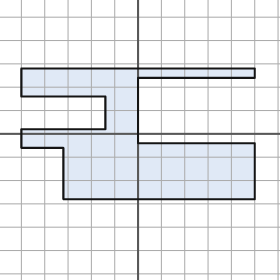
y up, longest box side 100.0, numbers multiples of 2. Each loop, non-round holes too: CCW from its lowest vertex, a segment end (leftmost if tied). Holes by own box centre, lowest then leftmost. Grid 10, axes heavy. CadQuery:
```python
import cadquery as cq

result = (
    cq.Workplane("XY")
    .moveTo(-32.0, -28.0)
    .lineTo(50.0, -28.0)
    .lineTo(50.0, -4.0)
    .lineTo(0.0, -4.0)
    .lineTo(0.0, 24.0)
    .lineTo(50.0, 24.0)
    .lineTo(50.0, 28.0)
    .lineTo(-50.0, 28.0)
    .lineTo(-50.0, 16.0)
    .lineTo(-14.0, 16.0)
    .lineTo(-14.0, 2.0)
    .lineTo(-50.0, 2.0)
    .lineTo(-50.0, -6.0)
    .lineTo(-32.0, -6.0)
    .close()
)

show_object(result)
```